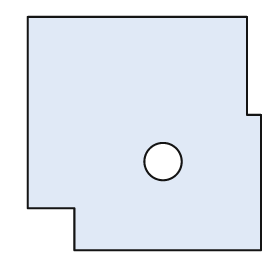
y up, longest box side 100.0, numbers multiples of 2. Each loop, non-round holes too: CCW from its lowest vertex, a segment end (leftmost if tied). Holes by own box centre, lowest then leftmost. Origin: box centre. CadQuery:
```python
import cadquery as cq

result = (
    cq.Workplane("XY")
    .moveTo(-30.0, -50.0)
    .lineTo(50.0, -50.0)
    .lineTo(50.0, 8.0)
    .lineTo(44.0, 8.0)
    .lineTo(44.0, 50.0)
    .lineTo(-50.0, 50.0)
    .lineTo(-50.0, -32.0)
    .lineTo(-30.0, -32.0)
    .close()
    .moveTo(8.0, -12.0)
    .circle(8.0)
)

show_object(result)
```